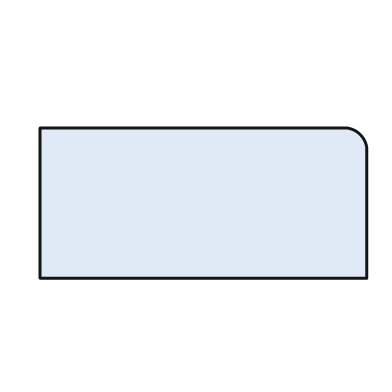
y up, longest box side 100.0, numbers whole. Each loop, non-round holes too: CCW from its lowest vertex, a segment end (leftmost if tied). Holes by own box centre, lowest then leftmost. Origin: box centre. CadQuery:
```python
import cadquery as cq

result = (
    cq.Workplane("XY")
    .moveTo(-50.0, -23.0)
    .lineTo(50.0, -23.0)
    .lineTo(50.0, 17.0)
    .threePointArc((48.0, 21.0), (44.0, 23.0))
    .lineTo(-50.0, 23.0)
    .close()
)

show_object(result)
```